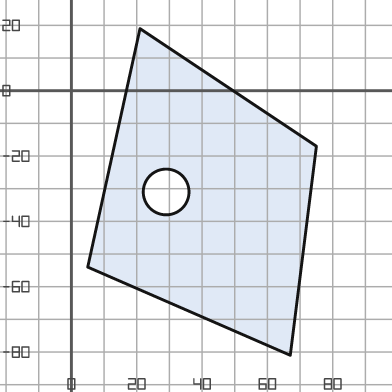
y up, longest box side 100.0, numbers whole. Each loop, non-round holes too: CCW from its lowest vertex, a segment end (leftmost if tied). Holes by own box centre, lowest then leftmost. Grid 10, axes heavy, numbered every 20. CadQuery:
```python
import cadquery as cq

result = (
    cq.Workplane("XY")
    .moveTo(67.0, -81.0)
    .lineTo(75.0, -17.0)
    .lineTo(21.0, 19.0)
    .lineTo(5.0, -54.0)
    .close()
    .moveTo(29.0, -31.0)
    .circle(7.0)
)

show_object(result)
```